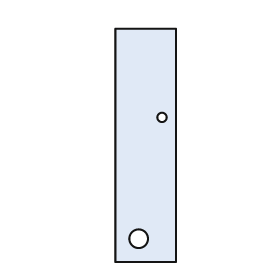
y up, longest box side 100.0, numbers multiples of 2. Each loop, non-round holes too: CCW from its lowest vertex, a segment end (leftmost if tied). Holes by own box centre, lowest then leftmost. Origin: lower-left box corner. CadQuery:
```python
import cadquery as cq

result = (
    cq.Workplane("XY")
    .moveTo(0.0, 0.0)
    .lineTo(26.0, 0.0)
    .lineTo(26.0, 100.0)
    .lineTo(0.0, 100.0)
    .close()
    .moveTo(10.0, 10.0)
    .circle(4.0)
    .moveTo(20.0, 62.0)
    .circle(2.0)
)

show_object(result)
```